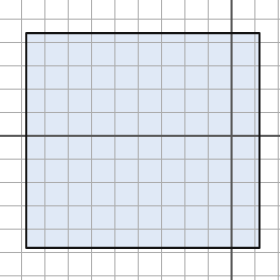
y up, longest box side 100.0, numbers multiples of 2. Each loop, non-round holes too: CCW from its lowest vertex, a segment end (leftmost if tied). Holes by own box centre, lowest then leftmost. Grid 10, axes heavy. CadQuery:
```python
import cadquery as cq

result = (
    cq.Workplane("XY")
    .moveTo(-88.0, -48.0)
    .lineTo(12.0, -48.0)
    .lineTo(12.0, 44.0)
    .lineTo(-88.0, 44.0)
    .close()
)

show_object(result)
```